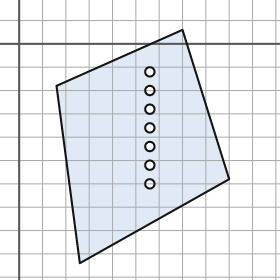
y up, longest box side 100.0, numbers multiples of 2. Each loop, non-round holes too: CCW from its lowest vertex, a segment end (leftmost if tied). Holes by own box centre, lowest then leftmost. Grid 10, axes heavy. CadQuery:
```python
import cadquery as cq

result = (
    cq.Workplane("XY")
    .moveTo(26.0, -94.0)
    .lineTo(90.0, -58.0)
    .lineTo(70.0, 6.0)
    .lineTo(16.0, -18.0)
    .close()
    .moveTo(56.0, -60.0)
    .circle(2.0)
    .moveTo(56.0, -52.0)
    .circle(2.0)
    .moveTo(56.0, -44.0)
    .circle(2.0)
    .moveTo(56.0, -36.0)
    .circle(2.0)
    .moveTo(56.0, -28.0)
    .circle(2.0)
    .moveTo(56.0, -20.0)
    .circle(2.0)
    .moveTo(56.0, -12.0)
    .circle(2.0)
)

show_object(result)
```